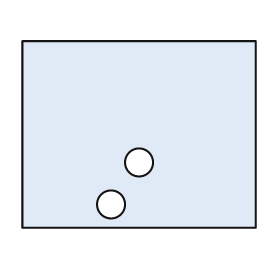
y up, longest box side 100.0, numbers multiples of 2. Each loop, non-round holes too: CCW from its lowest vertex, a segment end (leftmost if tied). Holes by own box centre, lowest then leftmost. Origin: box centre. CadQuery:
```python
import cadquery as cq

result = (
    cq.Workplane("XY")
    .moveTo(-50.0, -40.0)
    .lineTo(50.0, -40.0)
    .lineTo(50.0, 40.0)
    .lineTo(-50.0, 40.0)
    .close()
    .moveTo(-12.0, -30.0)
    .circle(6.0)
    .moveTo(0.0, -12.0)
    .circle(6.0)
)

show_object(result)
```